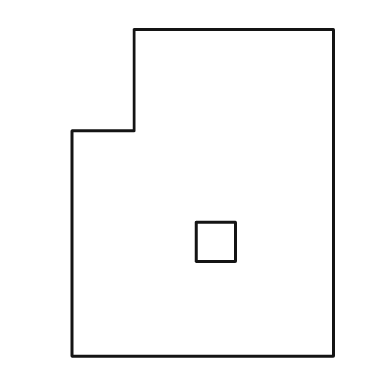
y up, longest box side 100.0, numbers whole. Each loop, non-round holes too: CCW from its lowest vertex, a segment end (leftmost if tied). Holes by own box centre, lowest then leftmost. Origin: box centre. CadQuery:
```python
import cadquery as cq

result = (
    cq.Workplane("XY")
    .moveTo(-40.0, -50.0)
    .lineTo(40.0, -50.0)
    .lineTo(40.0, 50.0)
    .lineTo(-21.0, 50.0)
    .lineTo(-21.0, 19.0)
    .lineTo(-40.0, 19.0)
    .close()
    .moveTo(-2.0, -21.0)
    .lineTo(10.0, -21.0)
    .lineTo(10.0, -9.0)
    .lineTo(-2.0, -9.0)
    .close()
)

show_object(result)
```